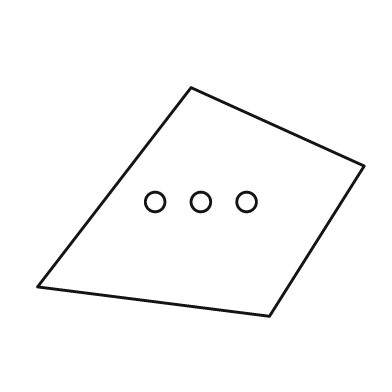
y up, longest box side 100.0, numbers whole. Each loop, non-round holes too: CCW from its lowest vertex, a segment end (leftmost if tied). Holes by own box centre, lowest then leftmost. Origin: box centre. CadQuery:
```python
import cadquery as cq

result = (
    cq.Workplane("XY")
    .moveTo(21.0, -35.0)
    .lineTo(50.0, 11.0)
    .lineTo(-3.0, 35.0)
    .lineTo(-50.0, -26.0)
    .close()
    .moveTo(-14.0, 0.0)
    .circle(3.0)
    .moveTo(0.0, 0.0)
    .circle(3.0)
    .moveTo(14.0, 0.0)
    .circle(3.0)
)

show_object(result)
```